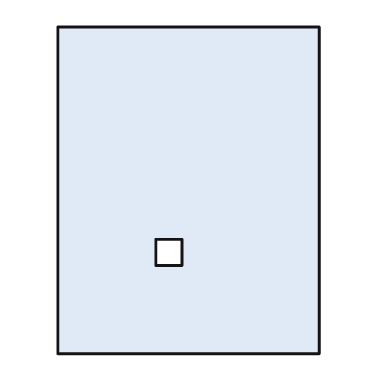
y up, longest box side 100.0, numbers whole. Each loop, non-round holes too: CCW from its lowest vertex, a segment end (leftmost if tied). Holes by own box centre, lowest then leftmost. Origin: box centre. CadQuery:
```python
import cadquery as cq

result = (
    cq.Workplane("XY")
    .moveTo(-40.0, -50.0)
    .lineTo(40.0, -50.0)
    .lineTo(40.0, 50.0)
    .lineTo(-40.0, 50.0)
    .close()
    .moveTo(-10.0, -23.0)
    .lineTo(-2.0, -23.0)
    .lineTo(-2.0, -15.0)
    .lineTo(-10.0, -15.0)
    .close()
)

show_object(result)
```